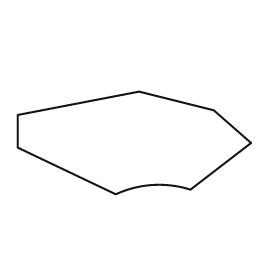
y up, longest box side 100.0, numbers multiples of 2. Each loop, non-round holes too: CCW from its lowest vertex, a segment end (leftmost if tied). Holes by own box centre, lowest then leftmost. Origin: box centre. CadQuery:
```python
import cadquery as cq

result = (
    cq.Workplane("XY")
    .moveTo(-8.0, -22.0)
    .threePointArc((8.0, -18.0), (24.0, -20.0))
    .lineTo(50.0, 0.0)
    .lineTo(34.0, 14.0)
    .lineTo(2.0, 22.0)
    .lineTo(-50.0, 12.0)
    .lineTo(-50.0, -2.0)
    .close()
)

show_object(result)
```